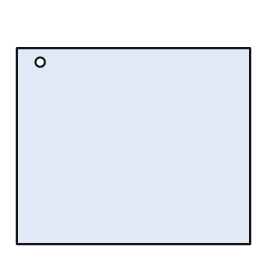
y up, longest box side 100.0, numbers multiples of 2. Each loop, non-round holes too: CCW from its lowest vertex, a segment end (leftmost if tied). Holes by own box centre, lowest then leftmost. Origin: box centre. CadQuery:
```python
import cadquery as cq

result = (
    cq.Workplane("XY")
    .moveTo(-50.0, -42.0)
    .lineTo(50.0, -42.0)
    .lineTo(50.0, 42.0)
    .lineTo(-50.0, 42.0)
    .close()
    .moveTo(-40.0, 36.0)
    .circle(2.0)
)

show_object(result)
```